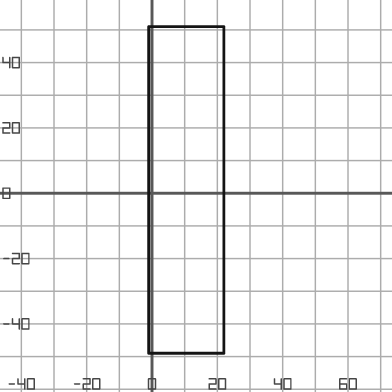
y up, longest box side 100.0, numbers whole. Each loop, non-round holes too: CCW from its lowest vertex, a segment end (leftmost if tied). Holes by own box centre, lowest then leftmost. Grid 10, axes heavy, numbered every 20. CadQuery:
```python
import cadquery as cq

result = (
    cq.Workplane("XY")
    .moveTo(-1.0, -49.0)
    .lineTo(22.0, -49.0)
    .lineTo(22.0, 51.0)
    .lineTo(-1.0, 51.0)
    .close()
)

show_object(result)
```